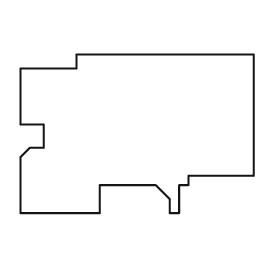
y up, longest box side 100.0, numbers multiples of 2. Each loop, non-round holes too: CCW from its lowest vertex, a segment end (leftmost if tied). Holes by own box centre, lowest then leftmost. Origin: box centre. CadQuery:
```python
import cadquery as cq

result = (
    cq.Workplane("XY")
    .moveTo(-50.0, -34.0)
    .lineTo(-16.0, -34.0)
    .lineTo(-16.0, -22.0)
    .lineTo(8.0, -22.0)
    .lineTo(14.0, -28.0)
    .lineTo(14.0, -34.0)
    .lineTo(18.0, -34.0)
    .lineTo(18.0, -22.0)
    .lineTo(22.0, -22.0)
    .lineTo(22.0, -18.0)
    .lineTo(50.0, -18.0)
    .lineTo(50.0, 34.0)
    .lineTo(-26.0, 34.0)
    .lineTo(-26.0, 28.0)
    .lineTo(-50.0, 28.0)
    .lineTo(-50.0, 4.0)
    .lineTo(-40.0, 4.0)
    .lineTo(-40.0, -6.0)
    .lineTo(-46.0, -6.0)
    .lineTo(-50.0, -10.0)
    .close()
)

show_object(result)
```